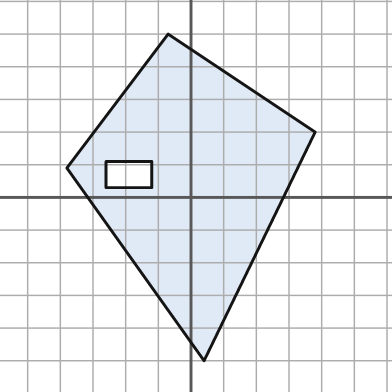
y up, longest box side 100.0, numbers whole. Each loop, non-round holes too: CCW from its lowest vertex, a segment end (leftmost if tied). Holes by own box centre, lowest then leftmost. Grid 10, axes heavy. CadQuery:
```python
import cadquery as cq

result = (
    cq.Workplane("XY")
    .moveTo(4.0, -50.0)
    .lineTo(38.0, 20.0)
    .lineTo(-7.0, 50.0)
    .lineTo(-38.0, 9.0)
    .close()
    .moveTo(-26.0, 3.0)
    .lineTo(-12.0, 3.0)
    .lineTo(-12.0, 11.0)
    .lineTo(-26.0, 11.0)
    .close()
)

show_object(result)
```